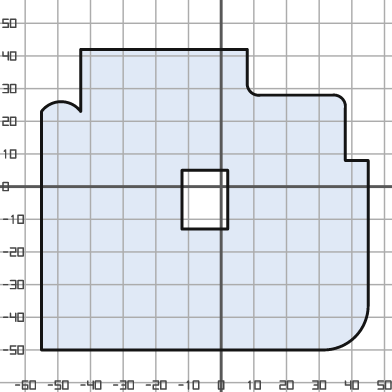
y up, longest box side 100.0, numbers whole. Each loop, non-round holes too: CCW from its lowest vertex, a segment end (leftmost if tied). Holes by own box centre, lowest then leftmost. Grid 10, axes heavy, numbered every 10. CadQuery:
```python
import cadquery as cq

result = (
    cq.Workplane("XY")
    .moveTo(-55.0, -50.0)
    .lineTo(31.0, -50.0)
    .threePointArc((41.0, -46.0), (45.0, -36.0))
    .lineTo(45.0, 8.0)
    .lineTo(38.0, 8.0)
    .lineTo(38.0, 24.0)
    .threePointArc((37.0, 27.0), (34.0, 28.0))
    .lineTo(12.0, 28.0)
    .threePointArc((9.0, 29.0), (8.0, 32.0))
    .lineTo(8.0, 42.0)
    .lineTo(-43.0, 42.0)
    .lineTo(-43.0, 23.0)
    .threePointArc((-49.0, 26.0), (-55.0, 23.0))
    .close()
    .moveTo(-12.0, -13.0)
    .lineTo(2.0, -13.0)
    .lineTo(2.0, 5.0)
    .lineTo(-12.0, 5.0)
    .close()
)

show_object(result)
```